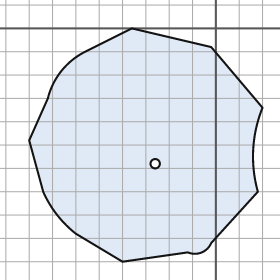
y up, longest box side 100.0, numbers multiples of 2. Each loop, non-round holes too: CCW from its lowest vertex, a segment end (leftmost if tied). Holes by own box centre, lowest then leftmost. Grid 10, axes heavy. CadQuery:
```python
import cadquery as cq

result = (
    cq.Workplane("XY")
    .moveTo(-40.0, -100.0)
    .lineTo(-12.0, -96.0)
    .threePointArc((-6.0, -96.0), (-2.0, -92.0))
    .lineTo(18.0, -70.0)
    .threePointArc((16.0, -52.0), (20.0, -34.0))
    .lineTo(-2.0, -8.0)
    .lineTo(-36.0, 0.0)
    .lineTo(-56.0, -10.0)
    .threePointArc((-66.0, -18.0), (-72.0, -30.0))
    .lineTo(-80.0, -48.0)
    .lineTo(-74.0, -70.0)
    .threePointArc((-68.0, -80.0), (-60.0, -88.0))
    .close()
    .moveTo(-26.0, -58.0)
    .circle(2.0)
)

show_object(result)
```